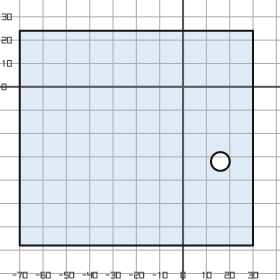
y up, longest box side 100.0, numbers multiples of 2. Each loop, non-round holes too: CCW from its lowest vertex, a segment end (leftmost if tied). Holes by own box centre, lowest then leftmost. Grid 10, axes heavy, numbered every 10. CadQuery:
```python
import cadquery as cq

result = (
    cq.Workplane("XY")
    .moveTo(-70.0, -68.0)
    .lineTo(30.0, -68.0)
    .lineTo(30.0, 24.0)
    .lineTo(-70.0, 24.0)
    .close()
    .moveTo(16.0, -32.0)
    .circle(4.0)
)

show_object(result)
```